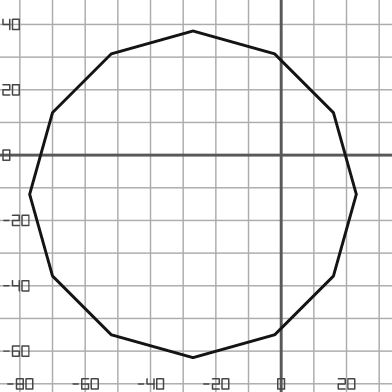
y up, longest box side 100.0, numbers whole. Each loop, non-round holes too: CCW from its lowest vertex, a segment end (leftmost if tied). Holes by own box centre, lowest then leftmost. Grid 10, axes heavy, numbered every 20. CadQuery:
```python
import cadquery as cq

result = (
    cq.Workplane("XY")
    .moveTo(-27.0, -62.0)
    .lineTo(-2.0, -55.0)
    .lineTo(16.0, -37.0)
    .lineTo(23.0, -12.0)
    .lineTo(16.0, 13.0)
    .lineTo(-2.0, 31.0)
    .lineTo(-27.0, 38.0)
    .lineTo(-52.0, 31.0)
    .lineTo(-70.0, 13.0)
    .lineTo(-77.0, -12.0)
    .lineTo(-70.0, -37.0)
    .lineTo(-52.0, -55.0)
    .close()
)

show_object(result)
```